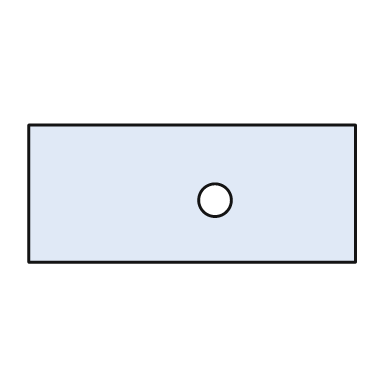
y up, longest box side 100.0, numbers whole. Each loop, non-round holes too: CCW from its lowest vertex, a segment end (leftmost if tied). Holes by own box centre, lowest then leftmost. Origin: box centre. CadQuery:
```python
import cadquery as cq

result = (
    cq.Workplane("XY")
    .moveTo(-50.0, -21.0)
    .lineTo(50.0, -21.0)
    .lineTo(50.0, 21.0)
    .lineTo(-50.0, 21.0)
    .close()
    .moveTo(7.0, -2.0)
    .circle(5.0)
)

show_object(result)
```